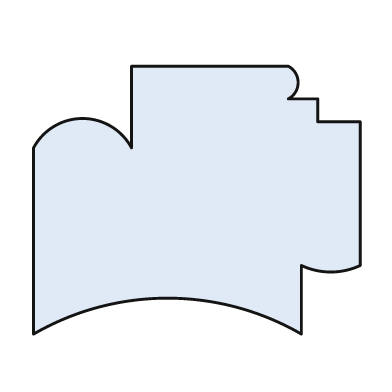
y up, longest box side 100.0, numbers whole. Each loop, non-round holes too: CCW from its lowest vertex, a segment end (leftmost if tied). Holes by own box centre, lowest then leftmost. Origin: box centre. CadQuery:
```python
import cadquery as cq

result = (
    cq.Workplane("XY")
    .moveTo(-50.0, -41.0)
    .threePointArc((-9.0, -30.0), (32.0, -41.0))
    .lineTo(32.0, -20.0)
    .threePointArc((41.0, -22.0), (50.0, -20.0))
    .lineTo(50.0, 24.0)
    .lineTo(37.0, 24.0)
    .lineTo(37.0, 31.0)
    .lineTo(28.0, 31.0)
    .threePointArc((31.0, 36.0), (28.0, 41.0))
    .lineTo(-20.0, 41.0)
    .lineTo(-20.0, 16.0)
    .threePointArc((-35.0, 25.0), (-50.0, 16.0))
    .close()
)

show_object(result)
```